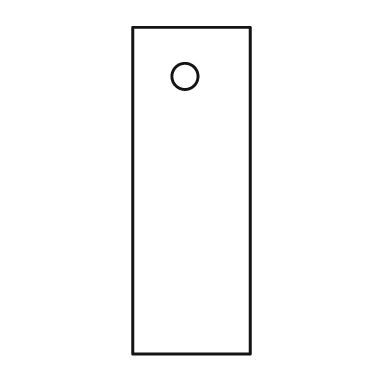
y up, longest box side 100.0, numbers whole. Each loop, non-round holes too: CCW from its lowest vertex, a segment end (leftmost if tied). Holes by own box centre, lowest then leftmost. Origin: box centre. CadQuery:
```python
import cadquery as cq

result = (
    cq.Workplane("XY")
    .moveTo(-18.0, -50.0)
    .lineTo(18.0, -50.0)
    .lineTo(18.0, 50.0)
    .lineTo(-18.0, 50.0)
    .close()
    .moveTo(-2.0, 35.0)
    .circle(4.0)
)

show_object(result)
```